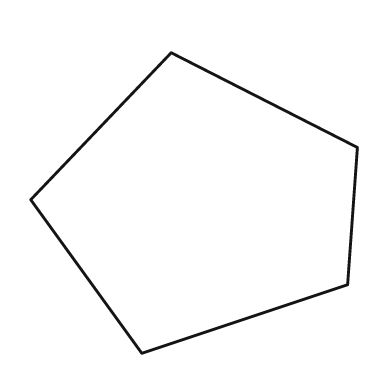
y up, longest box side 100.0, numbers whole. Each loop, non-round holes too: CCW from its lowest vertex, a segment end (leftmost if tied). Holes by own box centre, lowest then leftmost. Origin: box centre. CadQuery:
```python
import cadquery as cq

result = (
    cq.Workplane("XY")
    .moveTo(-16.0, -46.0)
    .lineTo(47.0, -25.0)
    .lineTo(50.0, 17.0)
    .lineTo(-7.0, 46.0)
    .lineTo(-50.0, 1.0)
    .close()
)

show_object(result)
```